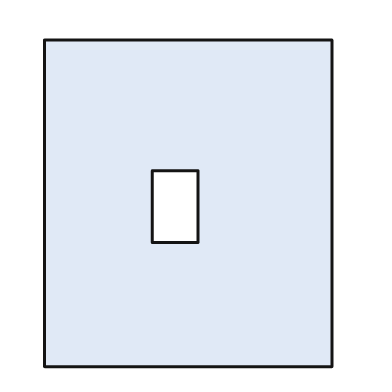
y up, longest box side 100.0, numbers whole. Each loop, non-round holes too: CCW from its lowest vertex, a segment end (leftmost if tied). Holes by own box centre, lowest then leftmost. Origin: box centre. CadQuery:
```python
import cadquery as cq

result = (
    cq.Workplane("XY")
    .moveTo(-44.0, -50.0)
    .lineTo(44.0, -50.0)
    .lineTo(44.0, 50.0)
    .lineTo(-44.0, 50.0)
    .close()
    .moveTo(-11.0, -12.0)
    .lineTo(3.0, -12.0)
    .lineTo(3.0, 10.0)
    .lineTo(-11.0, 10.0)
    .close()
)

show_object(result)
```